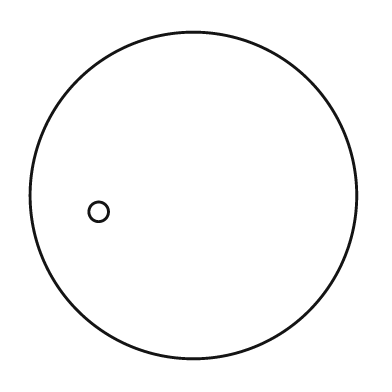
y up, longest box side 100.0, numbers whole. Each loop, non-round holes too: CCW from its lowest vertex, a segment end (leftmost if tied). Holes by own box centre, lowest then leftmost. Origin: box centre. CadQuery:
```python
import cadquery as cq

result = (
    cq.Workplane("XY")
    .moveTo(0.0, 0.0)
    .circle(50.0)
    .moveTo(-29.0, -5.0)
    .circle(3.0)
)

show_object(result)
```